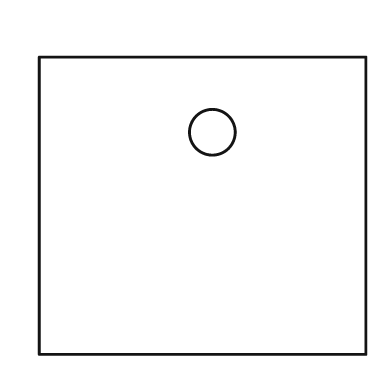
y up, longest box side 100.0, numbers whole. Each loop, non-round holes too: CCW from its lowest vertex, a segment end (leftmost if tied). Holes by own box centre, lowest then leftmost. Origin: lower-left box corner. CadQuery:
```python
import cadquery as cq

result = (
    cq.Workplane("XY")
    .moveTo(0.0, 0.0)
    .lineTo(100.0, 0.0)
    .lineTo(100.0, 91.0)
    .lineTo(0.0, 91.0)
    .close()
    .moveTo(53.0, 68.0)
    .circle(7.0)
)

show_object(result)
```